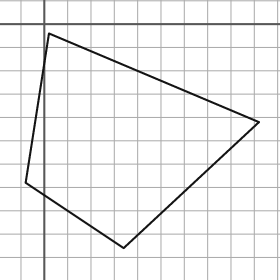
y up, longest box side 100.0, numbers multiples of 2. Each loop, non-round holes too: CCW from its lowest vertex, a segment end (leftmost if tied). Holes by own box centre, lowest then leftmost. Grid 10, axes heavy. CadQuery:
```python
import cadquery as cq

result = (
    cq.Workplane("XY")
    .moveTo(34.0, -96.0)
    .lineTo(92.0, -42.0)
    .lineTo(2.0, -4.0)
    .lineTo(-8.0, -68.0)
    .close()
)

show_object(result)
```